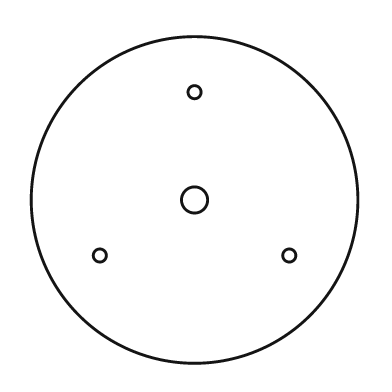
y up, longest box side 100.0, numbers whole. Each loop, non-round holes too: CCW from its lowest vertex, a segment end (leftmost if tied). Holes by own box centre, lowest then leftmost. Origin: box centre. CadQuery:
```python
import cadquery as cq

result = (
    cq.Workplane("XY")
    .moveTo(0.0, 0.0)
    .circle(50.0)
    .moveTo(-29.0, -17.0)
    .circle(2.0)
    .moveTo(29.0, -17.0)
    .circle(2.0)
    .moveTo(0.0, 0.0)
    .circle(4.0)
    .moveTo(0.0, 33.0)
    .circle(2.0)
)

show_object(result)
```